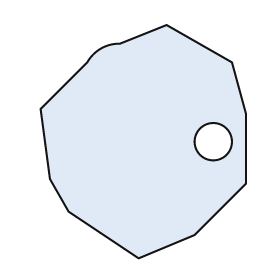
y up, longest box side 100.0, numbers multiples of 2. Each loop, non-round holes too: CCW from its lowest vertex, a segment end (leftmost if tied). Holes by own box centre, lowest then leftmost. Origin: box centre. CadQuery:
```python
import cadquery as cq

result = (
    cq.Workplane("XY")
    .moveTo(-2.0, -50.0)
    .lineTo(22.0, -40.0)
    .lineTo(44.0, -18.0)
    .lineTo(44.0, 12.0)
    .lineTo(38.0, 34.0)
    .lineTo(10.0, 50.0)
    .lineTo(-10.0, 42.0)
    .threePointArc((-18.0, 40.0), (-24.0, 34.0))
    .lineTo(-44.0, 14.0)
    .lineTo(-40.0, -16.0)
    .lineTo(-32.0, -30.0)
    .close()
    .moveTo(30.0, 0.0)
    .circle(8.0)
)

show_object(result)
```